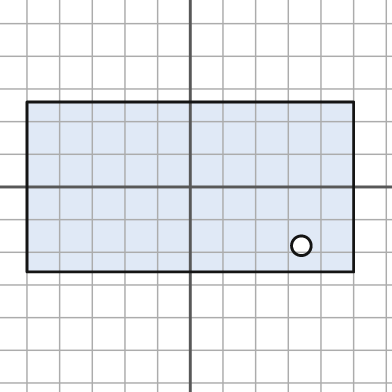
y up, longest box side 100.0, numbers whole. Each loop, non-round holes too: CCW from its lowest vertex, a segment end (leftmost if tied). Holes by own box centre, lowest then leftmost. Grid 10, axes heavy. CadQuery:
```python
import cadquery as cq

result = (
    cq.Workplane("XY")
    .moveTo(-50.0, -26.0)
    .lineTo(50.0, -26.0)
    .lineTo(50.0, 26.0)
    .lineTo(-50.0, 26.0)
    .close()
    .moveTo(34.0, -18.0)
    .circle(3.0)
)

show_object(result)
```